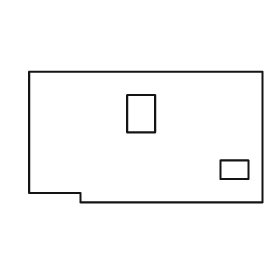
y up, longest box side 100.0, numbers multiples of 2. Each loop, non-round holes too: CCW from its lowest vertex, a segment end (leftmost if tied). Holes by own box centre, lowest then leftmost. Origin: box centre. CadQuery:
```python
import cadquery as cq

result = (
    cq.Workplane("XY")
    .moveTo(-28.0, -28.0)
    .lineTo(50.0, -28.0)
    .lineTo(50.0, 28.0)
    .lineTo(-50.0, 28.0)
    .lineTo(-50.0, -24.0)
    .lineTo(-28.0, -24.0)
    .close()
    .moveTo(32.0, -18.0)
    .lineTo(44.0, -18.0)
    .lineTo(44.0, -10.0)
    .lineTo(32.0, -10.0)
    .close()
    .moveTo(-8.0, 2.0)
    .lineTo(4.0, 2.0)
    .lineTo(4.0, 18.0)
    .lineTo(-8.0, 18.0)
    .close()
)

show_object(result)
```